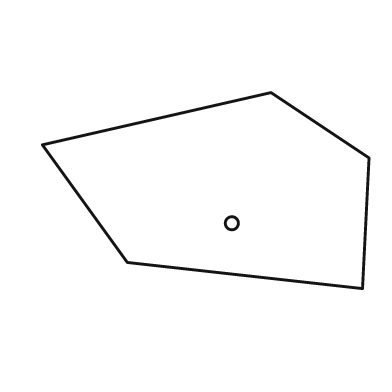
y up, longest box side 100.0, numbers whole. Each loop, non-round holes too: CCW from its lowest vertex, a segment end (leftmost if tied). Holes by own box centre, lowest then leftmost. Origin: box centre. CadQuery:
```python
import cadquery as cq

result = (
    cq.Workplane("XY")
    .moveTo(48.0, -30.0)
    .lineTo(50.0, 10.0)
    .lineTo(20.0, 30.0)
    .lineTo(-50.0, 14.0)
    .lineTo(-24.0, -22.0)
    .close()
    .moveTo(8.0, -10.0)
    .circle(2.0)
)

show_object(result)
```